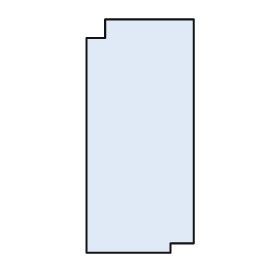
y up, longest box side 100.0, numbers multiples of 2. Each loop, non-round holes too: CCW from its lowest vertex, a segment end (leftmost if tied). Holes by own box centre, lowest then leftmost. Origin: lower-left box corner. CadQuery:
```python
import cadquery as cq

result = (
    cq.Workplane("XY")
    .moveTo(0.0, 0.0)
    .lineTo(36.0, 0.0)
    .lineTo(36.0, 4.0)
    .lineTo(46.0, 4.0)
    .lineTo(46.0, 100.0)
    .lineTo(8.0, 100.0)
    .lineTo(8.0, 92.0)
    .lineTo(0.0, 92.0)
    .close()
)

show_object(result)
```